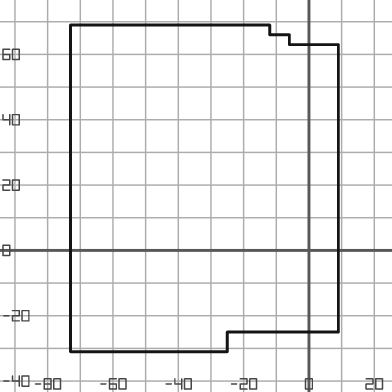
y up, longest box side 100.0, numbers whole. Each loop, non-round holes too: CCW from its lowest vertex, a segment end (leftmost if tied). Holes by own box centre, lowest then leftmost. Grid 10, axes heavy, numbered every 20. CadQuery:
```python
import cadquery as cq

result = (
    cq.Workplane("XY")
    .moveTo(-73.0, -31.0)
    .lineTo(-25.0, -31.0)
    .lineTo(-25.0, -25.0)
    .lineTo(9.0, -25.0)
    .lineTo(9.0, 63.0)
    .lineTo(-6.0, 63.0)
    .lineTo(-6.0, 66.0)
    .lineTo(-12.0, 66.0)
    .lineTo(-12.0, 69.0)
    .lineTo(-73.0, 69.0)
    .close()
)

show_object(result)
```